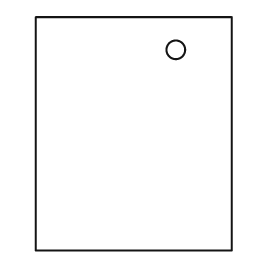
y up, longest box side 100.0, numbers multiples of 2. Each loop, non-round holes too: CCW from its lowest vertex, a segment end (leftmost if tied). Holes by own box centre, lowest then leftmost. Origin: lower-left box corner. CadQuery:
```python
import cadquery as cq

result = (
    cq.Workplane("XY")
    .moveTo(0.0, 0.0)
    .lineTo(84.0, 0.0)
    .lineTo(84.0, 100.0)
    .lineTo(0.0, 100.0)
    .close()
    .moveTo(60.0, 86.0)
    .circle(4.0)
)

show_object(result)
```